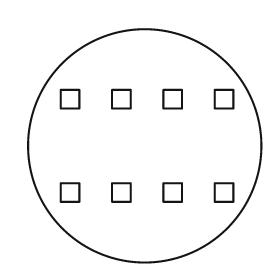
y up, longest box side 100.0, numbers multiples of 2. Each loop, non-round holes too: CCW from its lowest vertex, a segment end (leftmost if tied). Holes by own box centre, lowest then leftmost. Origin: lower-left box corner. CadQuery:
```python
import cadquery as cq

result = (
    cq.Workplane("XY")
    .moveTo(50.0, 50.0)
    .circle(50.0)
    .moveTo(14.0, 26.0)
    .lineTo(22.0, 26.0)
    .lineTo(22.0, 34.0)
    .lineTo(14.0, 34.0)
    .close()
    .moveTo(36.0, 26.0)
    .lineTo(44.0, 26.0)
    .lineTo(44.0, 34.0)
    .lineTo(36.0, 34.0)
    .close()
    .moveTo(58.0, 26.0)
    .lineTo(66.0, 26.0)
    .lineTo(66.0, 34.0)
    .lineTo(58.0, 34.0)
    .close()
    .moveTo(80.0, 26.0)
    .lineTo(88.0, 26.0)
    .lineTo(88.0, 34.0)
    .lineTo(80.0, 34.0)
    .close()
    .moveTo(14.0, 66.0)
    .lineTo(22.0, 66.0)
    .lineTo(22.0, 74.0)
    .lineTo(14.0, 74.0)
    .close()
    .moveTo(36.0, 66.0)
    .lineTo(44.0, 66.0)
    .lineTo(44.0, 74.0)
    .lineTo(36.0, 74.0)
    .close()
    .moveTo(58.0, 66.0)
    .lineTo(66.0, 66.0)
    .lineTo(66.0, 74.0)
    .lineTo(58.0, 74.0)
    .close()
    .moveTo(80.0, 66.0)
    .lineTo(88.0, 66.0)
    .lineTo(88.0, 74.0)
    .lineTo(80.0, 74.0)
    .close()
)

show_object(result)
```